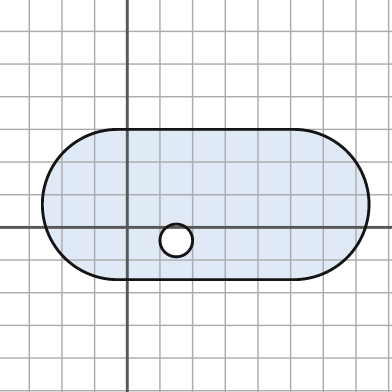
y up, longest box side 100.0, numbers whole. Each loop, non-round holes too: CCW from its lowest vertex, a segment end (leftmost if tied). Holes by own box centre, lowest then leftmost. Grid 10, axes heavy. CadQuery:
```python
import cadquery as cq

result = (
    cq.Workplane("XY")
    .moveTo(-3.0, -16.0)
    .lineTo(51.0, -16.0)
    .threePointArc((74.0, 7.0), (51.0, 30.0))
    .lineTo(-3.0, 30.0)
    .threePointArc((-26.0, 7.0), (-3.0, -16.0))
    .close()
    .moveTo(15.0, -4.0)
    .circle(5.0)
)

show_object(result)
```